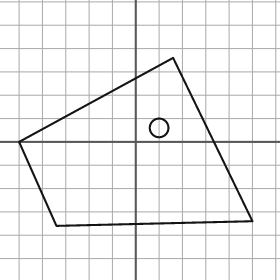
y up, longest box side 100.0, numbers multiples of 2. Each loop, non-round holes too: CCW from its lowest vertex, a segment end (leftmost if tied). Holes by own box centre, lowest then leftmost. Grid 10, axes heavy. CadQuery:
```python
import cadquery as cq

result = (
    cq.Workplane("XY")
    .moveTo(-34.0, -36.0)
    .lineTo(50.0, -34.0)
    .lineTo(16.0, 36.0)
    .lineTo(-50.0, 0.0)
    .close()
    .moveTo(10.0, 6.0)
    .circle(4.0)
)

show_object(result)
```